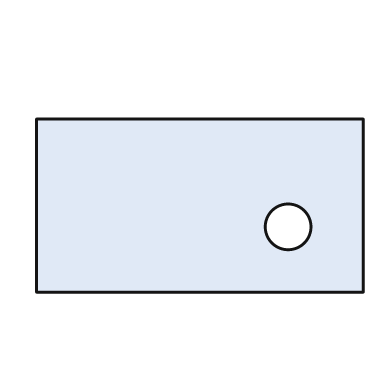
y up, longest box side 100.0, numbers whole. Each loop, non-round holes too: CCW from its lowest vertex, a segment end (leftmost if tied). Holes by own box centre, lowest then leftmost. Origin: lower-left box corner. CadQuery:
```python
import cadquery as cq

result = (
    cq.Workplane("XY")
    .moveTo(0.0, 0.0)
    .lineTo(100.0, 0.0)
    .lineTo(100.0, 53.0)
    .lineTo(0.0, 53.0)
    .close()
    .moveTo(77.0, 20.0)
    .circle(7.0)
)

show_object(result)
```